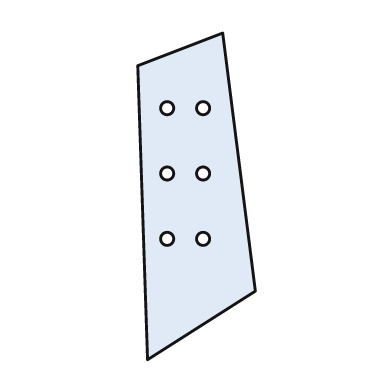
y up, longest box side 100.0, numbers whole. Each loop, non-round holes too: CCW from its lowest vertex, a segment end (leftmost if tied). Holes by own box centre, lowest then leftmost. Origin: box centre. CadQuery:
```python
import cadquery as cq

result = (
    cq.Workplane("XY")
    .moveTo(-15.0, -50.0)
    .lineTo(18.0, -29.0)
    .lineTo(8.0, 50.0)
    .lineTo(-18.0, 40.0)
    .close()
    .moveTo(-9.0, -13.0)
    .circle(2.0)
    .moveTo(2.0, -13.0)
    .circle(2.0)
    .moveTo(-9.0, 7.0)
    .circle(2.0)
    .moveTo(2.0, 7.0)
    .circle(2.0)
    .moveTo(-9.0, 27.0)
    .circle(2.0)
    .moveTo(2.0, 27.0)
    .circle(2.0)
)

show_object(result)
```